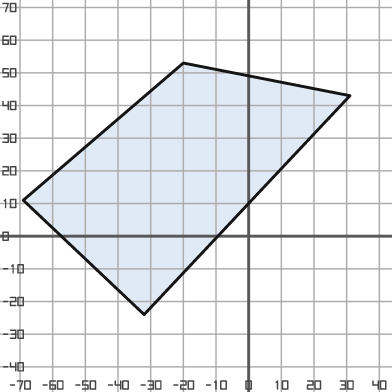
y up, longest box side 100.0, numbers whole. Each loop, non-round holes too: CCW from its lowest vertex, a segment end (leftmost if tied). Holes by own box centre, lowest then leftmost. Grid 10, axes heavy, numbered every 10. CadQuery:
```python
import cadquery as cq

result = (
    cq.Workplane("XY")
    .moveTo(-32.0, -24.0)
    .lineTo(31.0, 43.0)
    .lineTo(-20.0, 53.0)
    .lineTo(-69.0, 11.0)
    .close()
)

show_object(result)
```